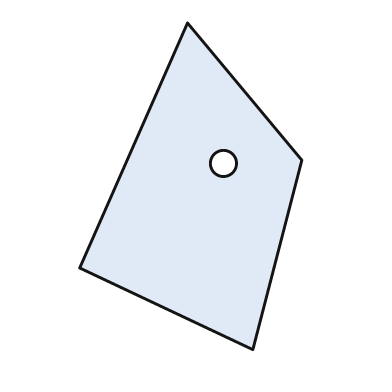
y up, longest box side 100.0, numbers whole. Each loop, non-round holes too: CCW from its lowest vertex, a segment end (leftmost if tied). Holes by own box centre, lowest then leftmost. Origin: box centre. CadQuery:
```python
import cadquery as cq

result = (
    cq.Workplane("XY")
    .moveTo(19.0, -50.0)
    .lineTo(34.0, 8.0)
    .lineTo(-1.0, 50.0)
    .lineTo(-34.0, -25.0)
    .close()
    .moveTo(10.0, 7.0)
    .circle(4.0)
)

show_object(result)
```